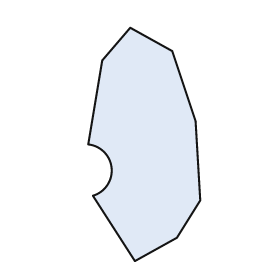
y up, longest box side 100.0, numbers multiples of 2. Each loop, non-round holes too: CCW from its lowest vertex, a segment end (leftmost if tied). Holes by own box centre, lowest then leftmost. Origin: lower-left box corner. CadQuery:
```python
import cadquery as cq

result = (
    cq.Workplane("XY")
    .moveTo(20.0, 0.0)
    .lineTo(38.0, 10.0)
    .lineTo(48.0, 26.0)
    .lineTo(46.0, 60.0)
    .lineTo(36.0, 90.0)
    .lineTo(18.0, 100.0)
    .lineTo(6.0, 86.0)
    .lineTo(0.0, 50.0)
    .threePointArc((10.0, 40.0), (2.0, 28.0))
    .close()
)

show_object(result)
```